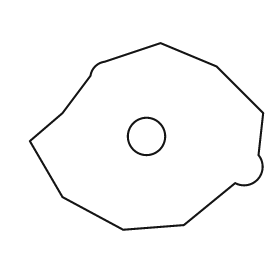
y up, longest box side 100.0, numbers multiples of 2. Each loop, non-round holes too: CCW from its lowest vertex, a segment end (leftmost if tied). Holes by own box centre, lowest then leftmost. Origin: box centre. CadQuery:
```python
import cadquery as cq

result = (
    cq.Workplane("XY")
    .moveTo(-10.0, -40.0)
    .lineTo(16.0, -38.0)
    .lineTo(38.0, -20.0)
    .threePointArc((48.0, -18.0), (48.0, -8.0))
    .lineTo(50.0, 10.0)
    .lineTo(30.0, 30.0)
    .lineTo(6.0, 40.0)
    .lineTo(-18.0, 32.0)
    .threePointArc((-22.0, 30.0), (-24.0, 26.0))
    .lineTo(-36.0, 10.0)
    .lineTo(-50.0, -2.0)
    .lineTo(-36.0, -26.0)
    .close()
    .moveTo(0.0, 0.0)
    .circle(8.0)
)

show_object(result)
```